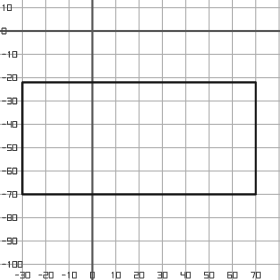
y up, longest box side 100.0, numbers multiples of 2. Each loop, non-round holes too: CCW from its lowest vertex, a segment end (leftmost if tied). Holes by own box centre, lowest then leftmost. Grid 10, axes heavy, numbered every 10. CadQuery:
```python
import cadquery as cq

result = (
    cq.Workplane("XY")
    .moveTo(-30.0, -70.0)
    .lineTo(70.0, -70.0)
    .lineTo(70.0, -22.0)
    .lineTo(-30.0, -22.0)
    .close()
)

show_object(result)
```